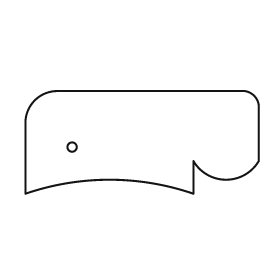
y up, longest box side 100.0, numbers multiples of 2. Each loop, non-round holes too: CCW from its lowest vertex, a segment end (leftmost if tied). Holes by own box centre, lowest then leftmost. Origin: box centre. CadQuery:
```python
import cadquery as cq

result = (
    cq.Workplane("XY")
    .moveTo(-50.0, -22.0)
    .threePointArc((-14.0, -16.0), (22.0, -22.0))
    .lineTo(22.0, -8.0)
    .threePointArc((36.0, -16.0), (50.0, -8.0))
    .lineTo(50.0, 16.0)
    .threePointArc((48.0, 20.0), (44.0, 22.0))
    .lineTo(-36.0, 22.0)
    .threePointArc((-46.0, 18.0), (-50.0, 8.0))
    .close()
    .moveTo(-30.0, -2.0)
    .circle(2.0)
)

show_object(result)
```